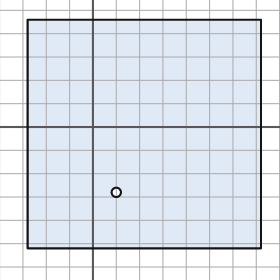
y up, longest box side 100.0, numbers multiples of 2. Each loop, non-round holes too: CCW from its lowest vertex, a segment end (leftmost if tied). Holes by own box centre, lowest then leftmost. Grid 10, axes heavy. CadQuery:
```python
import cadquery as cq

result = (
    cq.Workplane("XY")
    .moveTo(-28.0, -52.0)
    .lineTo(72.0, -52.0)
    .lineTo(72.0, 46.0)
    .lineTo(-28.0, 46.0)
    .close()
    .moveTo(10.0, -28.0)
    .circle(2.0)
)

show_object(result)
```